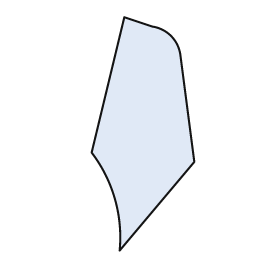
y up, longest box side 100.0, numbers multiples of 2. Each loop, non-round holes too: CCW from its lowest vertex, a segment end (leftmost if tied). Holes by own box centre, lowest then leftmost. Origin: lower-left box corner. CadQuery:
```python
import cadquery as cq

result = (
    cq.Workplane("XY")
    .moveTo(12.0, 0.0)
    .lineTo(44.0, 38.0)
    .lineTo(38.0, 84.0)
    .threePointArc((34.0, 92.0), (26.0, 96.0))
    .lineTo(14.0, 100.0)
    .lineTo(0.0, 42.0)
    .threePointArc((10.0, 22.0), (12.0, 0.0))
    .close()
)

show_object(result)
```